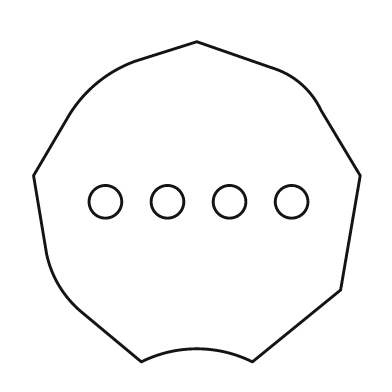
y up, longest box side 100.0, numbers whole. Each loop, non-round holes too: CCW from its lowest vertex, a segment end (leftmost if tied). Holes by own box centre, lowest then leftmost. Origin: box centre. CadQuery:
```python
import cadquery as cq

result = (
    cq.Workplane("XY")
    .moveTo(-17.0, -49.0)
    .threePointArc((0.0, -45.0), (17.0, -49.0))
    .lineTo(44.0, -27.0)
    .lineTo(50.0, 8.0)
    .lineTo(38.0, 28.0)
    .threePointArc((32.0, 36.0), (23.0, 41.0))
    .lineTo(0.0, 49.0)
    .lineTo(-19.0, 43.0)
    .threePointArc((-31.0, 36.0), (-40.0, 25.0))
    .lineTo(-50.0, 8.0)
    .lineTo(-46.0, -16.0)
    .threePointArc((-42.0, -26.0), (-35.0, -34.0))
    .close()
    .moveTo(-28.0, 0.0)
    .circle(5.0)
    .moveTo(-9.0, 0.0)
    .circle(5.0)
    .moveTo(10.0, 0.0)
    .circle(5.0)
    .moveTo(29.0, 0.0)
    .circle(5.0)
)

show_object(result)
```